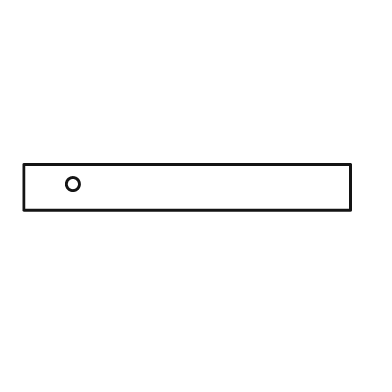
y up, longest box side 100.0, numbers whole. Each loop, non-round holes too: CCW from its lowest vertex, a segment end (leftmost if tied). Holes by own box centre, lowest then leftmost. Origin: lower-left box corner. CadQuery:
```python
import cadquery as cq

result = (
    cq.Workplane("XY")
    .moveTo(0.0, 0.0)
    .lineTo(100.0, 0.0)
    .lineTo(100.0, 14.0)
    .lineTo(0.0, 14.0)
    .close()
    .moveTo(15.0, 8.0)
    .circle(2.0)
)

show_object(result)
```